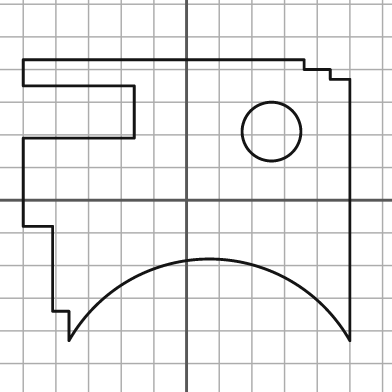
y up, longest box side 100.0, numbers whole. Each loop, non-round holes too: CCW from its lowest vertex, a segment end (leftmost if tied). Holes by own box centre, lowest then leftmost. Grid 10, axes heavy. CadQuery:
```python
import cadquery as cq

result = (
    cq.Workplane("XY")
    .moveTo(-36.0, -43.0)
    .threePointArc((7.0, -18.0), (50.0, -43.0))
    .lineTo(50.0, 37.0)
    .lineTo(44.0, 37.0)
    .lineTo(44.0, 40.0)
    .lineTo(36.0, 40.0)
    .lineTo(36.0, 43.0)
    .lineTo(-50.0, 43.0)
    .lineTo(-50.0, 35.0)
    .lineTo(-16.0, 35.0)
    .lineTo(-16.0, 19.0)
    .lineTo(-50.0, 19.0)
    .lineTo(-50.0, -8.0)
    .lineTo(-41.0, -8.0)
    .lineTo(-41.0, -34.0)
    .lineTo(-36.0, -34.0)
    .close()
    .moveTo(26.0, 21.0)
    .circle(9.0)
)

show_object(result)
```